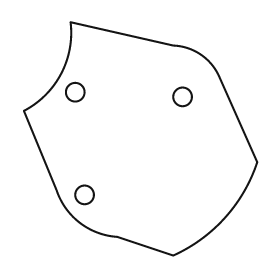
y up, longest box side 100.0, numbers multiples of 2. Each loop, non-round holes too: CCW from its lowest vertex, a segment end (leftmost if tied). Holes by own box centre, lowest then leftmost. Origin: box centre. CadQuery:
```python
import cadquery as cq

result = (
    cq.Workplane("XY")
    .moveTo(14.0, -50.0)
    .threePointArc((36.0, -34.0), (50.0, -10.0))
    .lineTo(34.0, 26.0)
    .threePointArc((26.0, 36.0), (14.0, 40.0))
    .lineTo(-30.0, 50.0)
    .threePointArc((-34.0, 28.0), (-50.0, 12.0))
    .lineTo(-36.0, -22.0)
    .threePointArc((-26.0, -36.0), (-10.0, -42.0))
    .close()
    .moveTo(-24.0, -24.0)
    .circle(4.0)
    .moveTo(18.0, 18.0)
    .circle(4.0)
    .moveTo(-28.0, 20.0)
    .circle(4.0)
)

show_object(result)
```